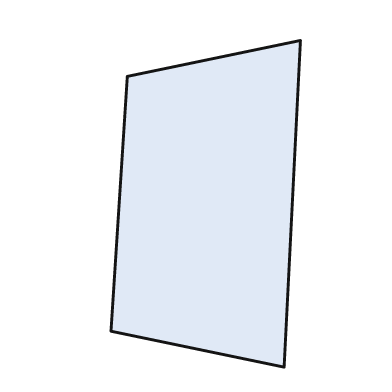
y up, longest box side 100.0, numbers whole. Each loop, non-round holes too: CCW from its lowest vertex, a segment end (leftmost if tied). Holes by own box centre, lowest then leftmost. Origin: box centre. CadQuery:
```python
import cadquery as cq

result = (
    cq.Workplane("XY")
    .moveTo(24.0, -50.0)
    .lineTo(29.0, 50.0)
    .lineTo(-24.0, 39.0)
    .lineTo(-29.0, -39.0)
    .close()
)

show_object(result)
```